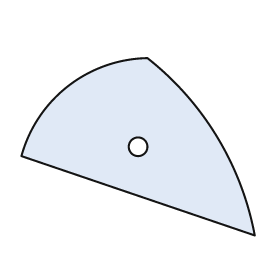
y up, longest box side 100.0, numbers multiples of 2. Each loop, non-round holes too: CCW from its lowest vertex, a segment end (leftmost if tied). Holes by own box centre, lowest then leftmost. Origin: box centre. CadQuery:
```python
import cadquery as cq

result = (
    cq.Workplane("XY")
    .moveTo(50.0, -38.0)
    .threePointArc((34.0, 4.0), (4.0, 38.0))
    .threePointArc((-30.0, 26.0), (-50.0, -4.0))
    .close()
    .moveTo(0.0, 0.0)
    .circle(4.0)
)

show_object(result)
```